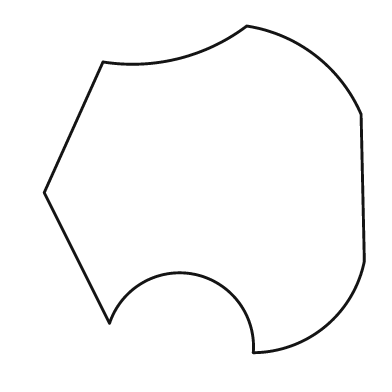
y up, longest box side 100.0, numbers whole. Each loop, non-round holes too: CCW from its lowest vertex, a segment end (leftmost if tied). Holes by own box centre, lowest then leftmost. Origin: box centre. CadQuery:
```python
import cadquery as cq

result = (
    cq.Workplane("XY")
    .moveTo(15.0, -50.0)
    .threePointArc((37.0, -42.0), (49.0, -22.0))
    .lineTo(48.0, 23.0)
    .threePointArc((34.0, 41.0), (13.0, 50.0))
    .threePointArc((-8.0, 40.0), (-31.0, 39.0))
    .lineTo(-49.0, -1.0)
    .lineTo(-29.0, -41.0)
    .threePointArc((-3.0, -26.0), (15.0, -50.0))
    .close()
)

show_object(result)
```